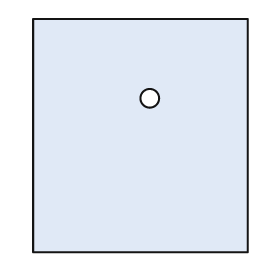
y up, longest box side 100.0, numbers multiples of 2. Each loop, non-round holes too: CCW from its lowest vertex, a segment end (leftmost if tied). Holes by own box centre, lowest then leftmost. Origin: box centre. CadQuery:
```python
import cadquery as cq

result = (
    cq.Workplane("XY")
    .moveTo(-46.0, -50.0)
    .lineTo(46.0, -50.0)
    .lineTo(46.0, 50.0)
    .lineTo(-46.0, 50.0)
    .close()
    .moveTo(4.0, 16.0)
    .circle(4.0)
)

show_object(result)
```